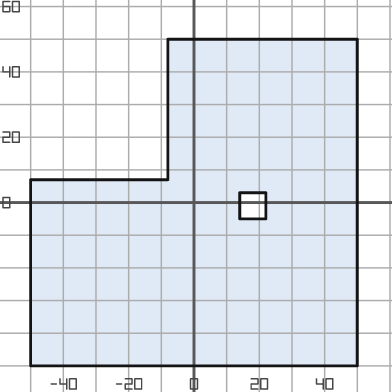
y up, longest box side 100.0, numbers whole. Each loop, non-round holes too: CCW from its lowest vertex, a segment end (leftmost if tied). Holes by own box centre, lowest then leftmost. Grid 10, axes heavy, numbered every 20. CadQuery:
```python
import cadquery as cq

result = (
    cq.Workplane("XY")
    .moveTo(-50.0, -50.0)
    .lineTo(50.0, -50.0)
    .lineTo(50.0, 50.0)
    .lineTo(-8.0, 50.0)
    .lineTo(-8.0, 7.0)
    .lineTo(-50.0, 7.0)
    .close()
    .moveTo(14.0, -5.0)
    .lineTo(22.0, -5.0)
    .lineTo(22.0, 3.0)
    .lineTo(14.0, 3.0)
    .close()
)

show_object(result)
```